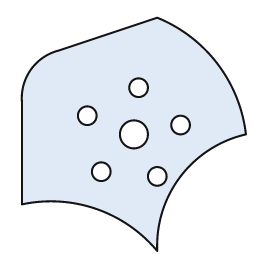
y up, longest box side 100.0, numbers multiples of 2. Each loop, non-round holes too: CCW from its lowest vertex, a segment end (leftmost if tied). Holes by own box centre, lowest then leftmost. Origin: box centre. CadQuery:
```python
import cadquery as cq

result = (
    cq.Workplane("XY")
    .moveTo(10.0, -50.0)
    .threePointArc((20.0, -18.0), (48.0, 0.0))
    .threePointArc((36.0, 30.0), (10.0, 50.0))
    .lineTo(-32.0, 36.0)
    .threePointArc((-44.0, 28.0), (-48.0, 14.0))
    .lineTo(-48.0, -30.0)
    .threePointArc((-16.0, -32.0), (10.0, -50.0))
    .close()
    .moveTo(10.0, -18.0)
    .circle(4.0)
    .moveTo(-14.0, -16.0)
    .circle(4.0)
    .moveTo(0.0, 0.0)
    .circle(6.0)
    .moveTo(20.0, 4.0)
    .circle(4.0)
    .moveTo(-20.0, 8.0)
    .circle(4.0)
    .moveTo(2.0, 20.0)
    .circle(4.0)
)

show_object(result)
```